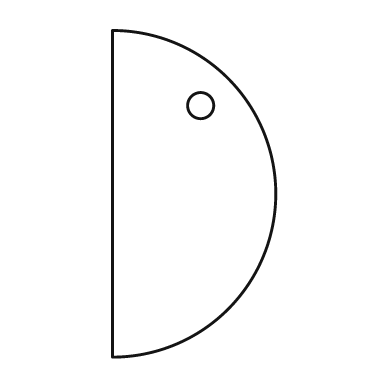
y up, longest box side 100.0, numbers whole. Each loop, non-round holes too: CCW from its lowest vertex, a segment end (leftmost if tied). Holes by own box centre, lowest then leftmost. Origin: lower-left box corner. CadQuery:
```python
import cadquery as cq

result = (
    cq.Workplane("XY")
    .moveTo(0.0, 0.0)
    .threePointArc((50.0, 50.0), (0.0, 100.0))
    .close()
    .moveTo(27.0, 77.0)
    .circle(4.0)
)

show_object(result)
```